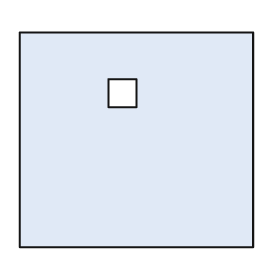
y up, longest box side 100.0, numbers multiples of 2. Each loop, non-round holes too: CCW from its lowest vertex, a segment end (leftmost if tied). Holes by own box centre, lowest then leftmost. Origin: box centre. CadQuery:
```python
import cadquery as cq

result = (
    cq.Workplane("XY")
    .moveTo(-50.0, -46.0)
    .lineTo(50.0, -46.0)
    .lineTo(50.0, 46.0)
    .lineTo(-50.0, 46.0)
    .close()
    .moveTo(-12.0, 14.0)
    .lineTo(0.0, 14.0)
    .lineTo(0.0, 26.0)
    .lineTo(-12.0, 26.0)
    .close()
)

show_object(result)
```